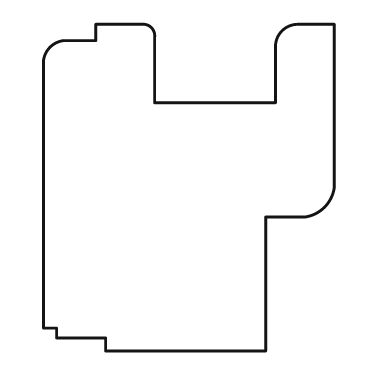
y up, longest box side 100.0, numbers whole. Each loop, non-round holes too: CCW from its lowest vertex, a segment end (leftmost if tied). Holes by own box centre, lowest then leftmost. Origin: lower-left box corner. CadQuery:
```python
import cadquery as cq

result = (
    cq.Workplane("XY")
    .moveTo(19.0, 0.0)
    .lineTo(68.0, 0.0)
    .lineTo(68.0, 41.0)
    .lineTo(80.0, 41.0)
    .threePointArc((86.0, 44.0), (89.0, 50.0))
    .lineTo(89.0, 100.0)
    .lineTo(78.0, 100.0)
    .threePointArc((73.0, 98.0), (71.0, 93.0))
    .lineTo(71.0, 76.0)
    .lineTo(34.0, 76.0)
    .lineTo(34.0, 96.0)
    .threePointArc((33.0, 99.0), (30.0, 100.0))
    .lineTo(16.0, 100.0)
    .lineTo(16.0, 95.0)
    .lineTo(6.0, 95.0)
    .threePointArc((2.0, 93.0), (0.0, 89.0))
    .lineTo(0.0, 7.0)
    .lineTo(4.0, 7.0)
    .lineTo(4.0, 4.0)
    .lineTo(19.0, 4.0)
    .close()
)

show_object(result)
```